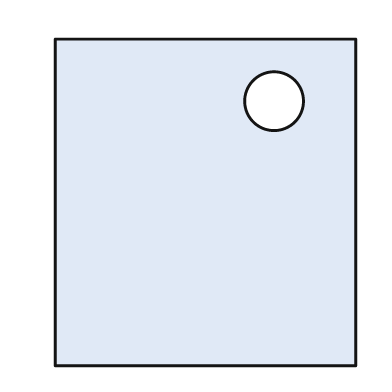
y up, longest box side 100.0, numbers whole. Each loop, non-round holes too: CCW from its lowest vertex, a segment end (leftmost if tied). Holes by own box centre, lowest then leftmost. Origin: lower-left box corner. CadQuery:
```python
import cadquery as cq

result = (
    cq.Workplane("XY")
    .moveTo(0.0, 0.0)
    .lineTo(92.0, 0.0)
    .lineTo(92.0, 100.0)
    .lineTo(0.0, 100.0)
    .close()
    .moveTo(67.0, 81.0)
    .circle(9.0)
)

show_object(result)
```